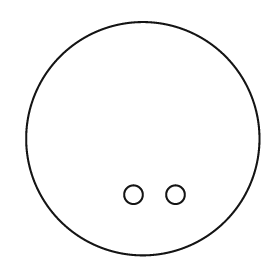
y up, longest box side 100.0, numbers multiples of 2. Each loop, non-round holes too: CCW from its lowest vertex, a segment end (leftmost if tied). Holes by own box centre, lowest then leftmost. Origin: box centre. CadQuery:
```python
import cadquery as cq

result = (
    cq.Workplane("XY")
    .moveTo(0.0, 0.0)
    .circle(50.0)
    .moveTo(-4.0, -24.0)
    .circle(4.0)
    .moveTo(14.0, -24.0)
    .circle(4.0)
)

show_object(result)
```